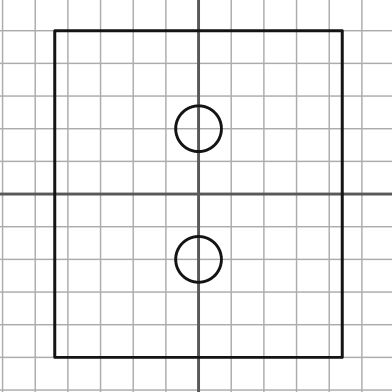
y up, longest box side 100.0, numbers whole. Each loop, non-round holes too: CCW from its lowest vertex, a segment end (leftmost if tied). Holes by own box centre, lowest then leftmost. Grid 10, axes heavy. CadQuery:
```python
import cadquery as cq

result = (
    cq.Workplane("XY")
    .moveTo(-44.0, -50.0)
    .lineTo(44.0, -50.0)
    .lineTo(44.0, 50.0)
    .lineTo(-44.0, 50.0)
    .close()
    .moveTo(0.0, -20.0)
    .circle(7.0)
    .moveTo(0.0, 20.0)
    .circle(7.0)
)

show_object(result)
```